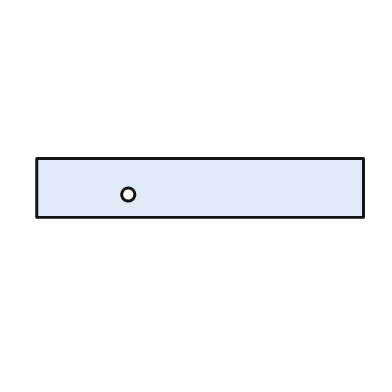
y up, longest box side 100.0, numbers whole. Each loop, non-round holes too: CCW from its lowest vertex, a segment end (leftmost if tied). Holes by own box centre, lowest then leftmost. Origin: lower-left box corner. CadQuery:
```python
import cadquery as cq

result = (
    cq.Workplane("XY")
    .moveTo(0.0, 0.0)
    .lineTo(100.0, 0.0)
    .lineTo(100.0, 18.0)
    .lineTo(0.0, 18.0)
    .close()
    .moveTo(28.0, 7.0)
    .circle(2.0)
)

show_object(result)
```